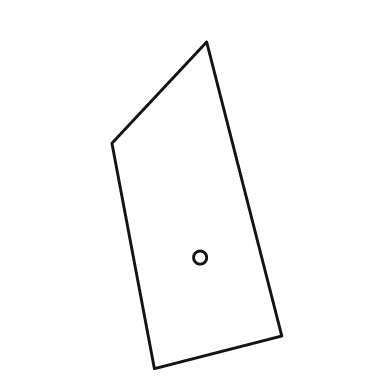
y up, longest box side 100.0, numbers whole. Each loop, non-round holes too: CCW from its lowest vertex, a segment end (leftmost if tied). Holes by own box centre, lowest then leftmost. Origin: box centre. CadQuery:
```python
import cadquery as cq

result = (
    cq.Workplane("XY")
    .moveTo(-13.0, -50.0)
    .lineTo(26.0, -40.0)
    .lineTo(3.0, 50.0)
    .lineTo(-26.0, 19.0)
    .close()
    .moveTo(1.0, -16.0)
    .circle(2.0)
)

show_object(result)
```